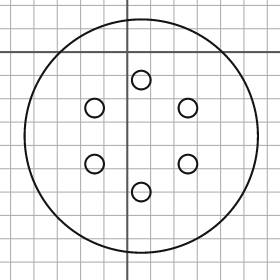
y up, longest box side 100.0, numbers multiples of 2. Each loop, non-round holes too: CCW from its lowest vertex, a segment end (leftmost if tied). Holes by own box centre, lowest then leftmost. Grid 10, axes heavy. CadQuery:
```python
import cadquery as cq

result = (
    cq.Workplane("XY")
    .moveTo(6.0, -36.0)
    .circle(50.0)
    .moveTo(6.0, -60.0)
    .circle(4.0)
    .moveTo(-14.0, -48.0)
    .circle(4.0)
    .moveTo(26.0, -48.0)
    .circle(4.0)
    .moveTo(-14.0, -24.0)
    .circle(4.0)
    .moveTo(26.0, -24.0)
    .circle(4.0)
    .moveTo(6.0, -12.0)
    .circle(4.0)
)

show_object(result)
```